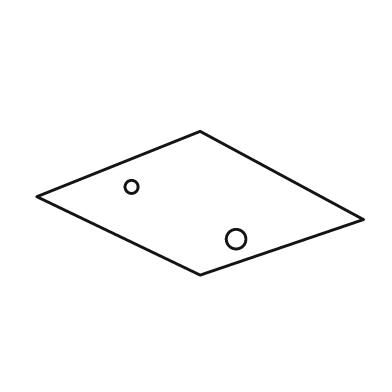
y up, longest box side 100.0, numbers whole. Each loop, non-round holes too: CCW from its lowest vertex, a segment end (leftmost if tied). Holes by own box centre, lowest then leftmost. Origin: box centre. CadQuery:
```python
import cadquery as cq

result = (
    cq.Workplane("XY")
    .moveTo(0.0, -22.0)
    .lineTo(50.0, -5.0)
    .lineTo(0.0, 22.0)
    .lineTo(-50.0, 2.0)
    .close()
    .moveTo(11.0, -11.0)
    .circle(3.0)
    .moveTo(-21.0, 5.0)
    .circle(2.0)
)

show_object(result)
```